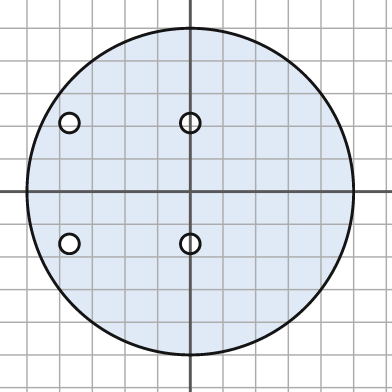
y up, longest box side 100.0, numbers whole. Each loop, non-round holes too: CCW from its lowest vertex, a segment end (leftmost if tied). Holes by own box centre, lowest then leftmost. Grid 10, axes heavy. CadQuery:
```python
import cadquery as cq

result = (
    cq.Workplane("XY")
    .moveTo(0.0, 0.0)
    .circle(50.0)
    .moveTo(-37.0, -16.0)
    .circle(3.0)
    .moveTo(0.0, -16.0)
    .circle(3.0)
    .moveTo(-37.0, 21.0)
    .circle(3.0)
    .moveTo(0.0, 21.0)
    .circle(3.0)
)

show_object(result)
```